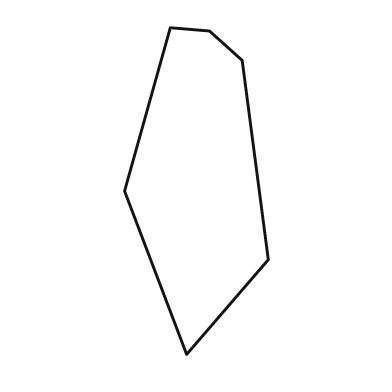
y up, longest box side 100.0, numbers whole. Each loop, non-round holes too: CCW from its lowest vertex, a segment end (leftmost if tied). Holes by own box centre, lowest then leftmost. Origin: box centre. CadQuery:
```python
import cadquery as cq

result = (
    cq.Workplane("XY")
    .moveTo(-3.0, -50.0)
    .lineTo(22.0, -21.0)
    .lineTo(14.0, 40.0)
    .lineTo(4.0, 49.0)
    .lineTo(-8.0, 50.0)
    .lineTo(-22.0, 0.0)
    .close()
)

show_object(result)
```